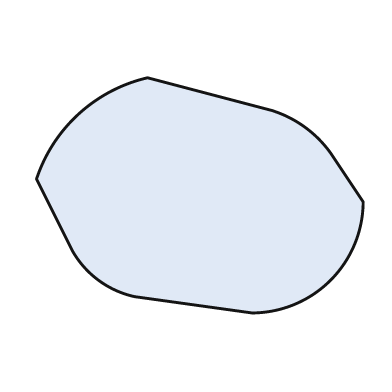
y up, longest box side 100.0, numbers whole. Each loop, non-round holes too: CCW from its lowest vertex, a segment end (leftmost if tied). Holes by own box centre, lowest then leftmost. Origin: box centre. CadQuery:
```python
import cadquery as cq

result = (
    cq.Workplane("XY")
    .moveTo(16.0, -36.0)
    .threePointArc((40.0, -26.0), (50.0, -2.0))
    .lineTo(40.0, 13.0)
    .threePointArc((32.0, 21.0), (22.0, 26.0))
    .lineTo(-16.0, 36.0)
    .threePointArc((-37.0, 25.0), (-50.0, 5.0))
    .lineTo(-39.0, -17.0)
    .threePointArc((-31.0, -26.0), (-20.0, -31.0))
    .close()
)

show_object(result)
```